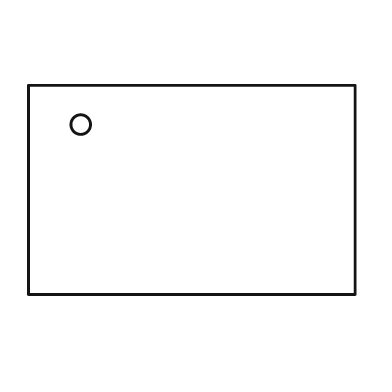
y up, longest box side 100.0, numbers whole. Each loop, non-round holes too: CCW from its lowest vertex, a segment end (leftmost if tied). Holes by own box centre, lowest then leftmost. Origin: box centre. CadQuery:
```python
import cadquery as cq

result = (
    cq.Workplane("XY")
    .moveTo(-50.0, -32.0)
    .lineTo(50.0, -32.0)
    .lineTo(50.0, 32.0)
    .lineTo(-50.0, 32.0)
    .close()
    .moveTo(-34.0, 20.0)
    .circle(3.0)
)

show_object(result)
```